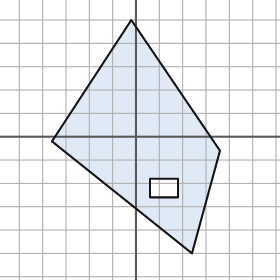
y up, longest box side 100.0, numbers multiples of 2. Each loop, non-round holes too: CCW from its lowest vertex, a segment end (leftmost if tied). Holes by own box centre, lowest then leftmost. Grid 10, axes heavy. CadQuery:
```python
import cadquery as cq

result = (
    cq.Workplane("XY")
    .moveTo(24.0, -50.0)
    .lineTo(36.0, -6.0)
    .lineTo(-2.0, 50.0)
    .lineTo(-36.0, -2.0)
    .close()
    .moveTo(6.0, -26.0)
    .lineTo(18.0, -26.0)
    .lineTo(18.0, -18.0)
    .lineTo(6.0, -18.0)
    .close()
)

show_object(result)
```